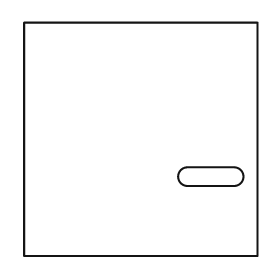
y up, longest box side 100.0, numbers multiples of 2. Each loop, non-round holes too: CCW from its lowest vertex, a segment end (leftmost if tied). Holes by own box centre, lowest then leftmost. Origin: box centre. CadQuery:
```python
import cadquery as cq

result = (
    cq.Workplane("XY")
    .moveTo(-50.0, -50.0)
    .lineTo(50.0, -50.0)
    .lineTo(50.0, 50.0)
    .lineTo(-50.0, 50.0)
    .close()
    .moveTo(20.0, -20.0)
    .lineTo(40.0, -20.0)
    .threePointArc((44.0, -16.0), (40.0, -12.0))
    .lineTo(20.0, -12.0)
    .threePointArc((16.0, -16.0), (20.0, -20.0))
    .close()
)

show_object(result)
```